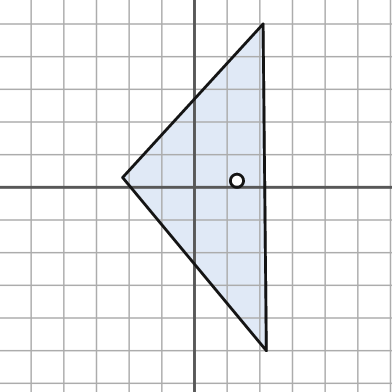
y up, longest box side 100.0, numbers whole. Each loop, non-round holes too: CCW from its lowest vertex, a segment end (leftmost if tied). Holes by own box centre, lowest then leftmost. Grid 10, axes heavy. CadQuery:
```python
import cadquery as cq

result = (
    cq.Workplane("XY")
    .moveTo(22.0, -50.0)
    .lineTo(21.0, 50.0)
    .lineTo(-22.0, 3.0)
    .close()
    .moveTo(13.0, 2.0)
    .circle(2.0)
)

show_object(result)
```